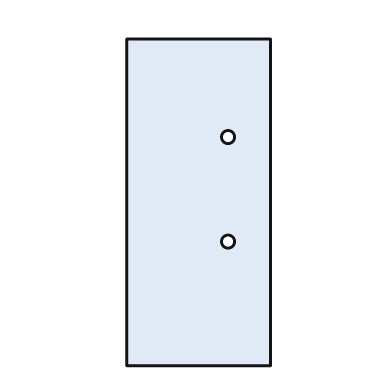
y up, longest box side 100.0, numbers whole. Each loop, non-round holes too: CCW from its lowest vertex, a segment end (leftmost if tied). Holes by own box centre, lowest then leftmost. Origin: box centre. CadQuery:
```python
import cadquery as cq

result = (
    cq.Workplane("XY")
    .moveTo(-22.0, -50.0)
    .lineTo(22.0, -50.0)
    .lineTo(22.0, 50.0)
    .lineTo(-22.0, 50.0)
    .close()
    .moveTo(9.0, -12.0)
    .circle(2.0)
    .moveTo(9.0, 20.0)
    .circle(2.0)
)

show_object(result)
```